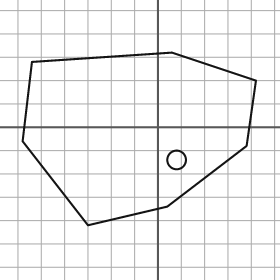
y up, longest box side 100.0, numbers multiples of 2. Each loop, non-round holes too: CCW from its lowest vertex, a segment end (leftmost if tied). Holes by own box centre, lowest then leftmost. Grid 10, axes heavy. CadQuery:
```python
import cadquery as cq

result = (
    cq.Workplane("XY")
    .moveTo(-30.0, -42.0)
    .lineTo(4.0, -34.0)
    .lineTo(38.0, -8.0)
    .lineTo(42.0, 20.0)
    .lineTo(6.0, 32.0)
    .lineTo(-54.0, 28.0)
    .lineTo(-58.0, -6.0)
    .close()
    .moveTo(8.0, -14.0)
    .circle(4.0)
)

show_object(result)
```